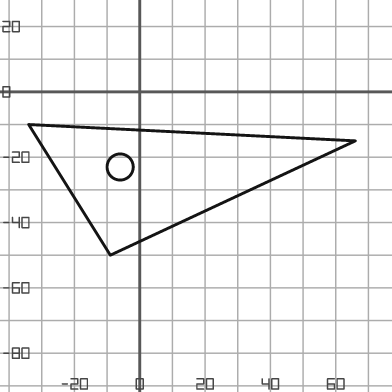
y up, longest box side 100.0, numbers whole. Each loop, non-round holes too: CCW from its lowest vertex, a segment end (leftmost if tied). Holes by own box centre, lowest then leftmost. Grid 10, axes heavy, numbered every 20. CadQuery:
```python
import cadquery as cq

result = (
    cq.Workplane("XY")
    .moveTo(-9.0, -50.0)
    .lineTo(66.0, -15.0)
    .lineTo(-34.0, -10.0)
    .close()
    .moveTo(-6.0, -23.0)
    .circle(4.0)
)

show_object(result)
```